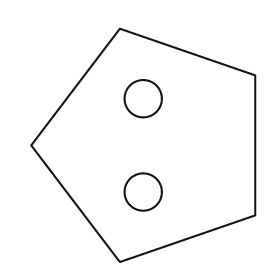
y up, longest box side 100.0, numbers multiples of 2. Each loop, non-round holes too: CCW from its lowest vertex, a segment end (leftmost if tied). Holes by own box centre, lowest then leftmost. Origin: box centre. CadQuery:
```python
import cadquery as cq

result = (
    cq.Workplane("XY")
    .moveTo(-10.0, -50.0)
    .lineTo(48.0, -30.0)
    .lineTo(48.0, 30.0)
    .lineTo(-10.0, 50.0)
    .lineTo(-48.0, 0.0)
    .close()
    .moveTo(0.0, -20.0)
    .circle(8.0)
    .moveTo(0.0, 20.0)
    .circle(8.0)
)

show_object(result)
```